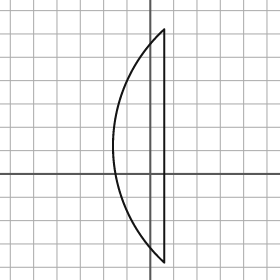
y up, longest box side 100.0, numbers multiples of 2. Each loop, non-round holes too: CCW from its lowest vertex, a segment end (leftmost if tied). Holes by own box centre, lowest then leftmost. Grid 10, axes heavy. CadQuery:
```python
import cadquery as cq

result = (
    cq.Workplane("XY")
    .moveTo(6.0, -38.0)
    .lineTo(6.0, 62.0)
    .threePointArc((-16.0, 12.0), (6.0, -38.0))
    .close()
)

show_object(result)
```